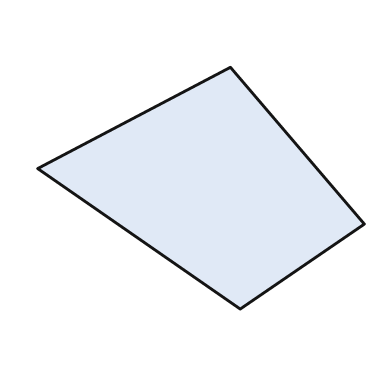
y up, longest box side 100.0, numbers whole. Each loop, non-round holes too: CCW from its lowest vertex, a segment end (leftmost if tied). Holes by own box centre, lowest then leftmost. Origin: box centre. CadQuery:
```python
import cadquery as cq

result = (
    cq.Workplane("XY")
    .moveTo(12.0, -37.0)
    .lineTo(50.0, -11.0)
    .lineTo(9.0, 37.0)
    .lineTo(-50.0, 6.0)
    .close()
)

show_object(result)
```